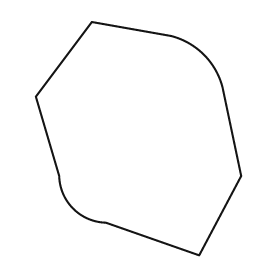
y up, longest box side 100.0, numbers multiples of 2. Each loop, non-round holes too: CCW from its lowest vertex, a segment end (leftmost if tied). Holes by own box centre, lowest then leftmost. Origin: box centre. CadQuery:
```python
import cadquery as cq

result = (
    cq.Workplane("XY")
    .moveTo(26.0, -50.0)
    .lineTo(44.0, -16.0)
    .lineTo(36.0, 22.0)
    .threePointArc((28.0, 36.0), (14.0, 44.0))
    .lineTo(-20.0, 50.0)
    .lineTo(-44.0, 18.0)
    .lineTo(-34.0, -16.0)
    .threePointArc((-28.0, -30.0), (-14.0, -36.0))
    .close()
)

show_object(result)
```